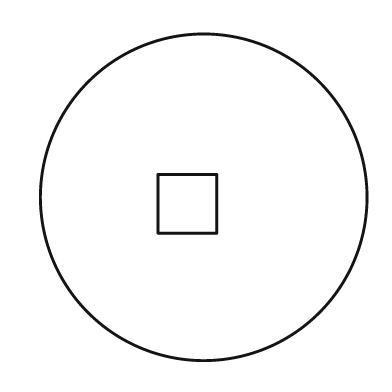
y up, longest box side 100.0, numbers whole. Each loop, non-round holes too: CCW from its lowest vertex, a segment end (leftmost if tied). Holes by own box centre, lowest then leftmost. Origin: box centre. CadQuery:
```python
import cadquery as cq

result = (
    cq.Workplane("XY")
    .moveTo(0.0, 0.0)
    .circle(50.0)
    .moveTo(-14.0, -11.0)
    .lineTo(4.0, -11.0)
    .lineTo(4.0, 7.0)
    .lineTo(-14.0, 7.0)
    .close()
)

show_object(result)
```